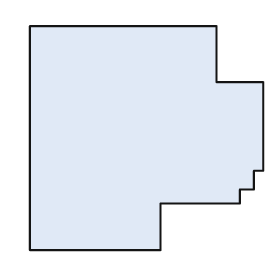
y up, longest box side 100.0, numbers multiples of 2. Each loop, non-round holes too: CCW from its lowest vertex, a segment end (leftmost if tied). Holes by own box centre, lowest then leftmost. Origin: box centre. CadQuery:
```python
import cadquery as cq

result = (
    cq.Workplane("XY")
    .moveTo(-50.0, -48.0)
    .lineTo(6.0, -48.0)
    .lineTo(6.0, -28.0)
    .lineTo(40.0, -28.0)
    .lineTo(40.0, -22.0)
    .lineTo(46.0, -22.0)
    .lineTo(46.0, -14.0)
    .lineTo(50.0, -14.0)
    .lineTo(50.0, 24.0)
    .lineTo(30.0, 24.0)
    .lineTo(30.0, 48.0)
    .lineTo(-50.0, 48.0)
    .close()
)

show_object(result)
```